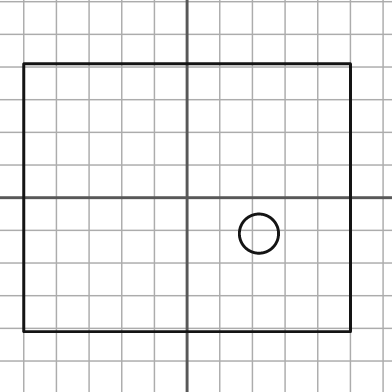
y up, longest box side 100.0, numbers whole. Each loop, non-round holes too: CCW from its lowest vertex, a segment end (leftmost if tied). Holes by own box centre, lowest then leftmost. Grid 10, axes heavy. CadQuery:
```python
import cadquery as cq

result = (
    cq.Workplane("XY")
    .moveTo(-50.0, -41.0)
    .lineTo(50.0, -41.0)
    .lineTo(50.0, 41.0)
    .lineTo(-50.0, 41.0)
    .close()
    .moveTo(22.0, -11.0)
    .circle(6.0)
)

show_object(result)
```